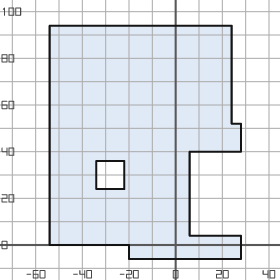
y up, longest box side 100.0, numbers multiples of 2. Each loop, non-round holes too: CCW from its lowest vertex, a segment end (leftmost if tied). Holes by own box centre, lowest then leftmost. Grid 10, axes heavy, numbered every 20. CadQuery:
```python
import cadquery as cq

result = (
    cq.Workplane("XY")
    .moveTo(-20.0, -6.0)
    .lineTo(28.0, -6.0)
    .lineTo(28.0, 4.0)
    .lineTo(6.0, 4.0)
    .lineTo(6.0, 40.0)
    .lineTo(28.0, 40.0)
    .lineTo(28.0, 52.0)
    .lineTo(24.0, 52.0)
    .lineTo(24.0, 94.0)
    .lineTo(-54.0, 94.0)
    .lineTo(-54.0, 0.0)
    .lineTo(-20.0, 0.0)
    .close()
    .moveTo(-34.0, 24.0)
    .lineTo(-22.0, 24.0)
    .lineTo(-22.0, 36.0)
    .lineTo(-34.0, 36.0)
    .close()
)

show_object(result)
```